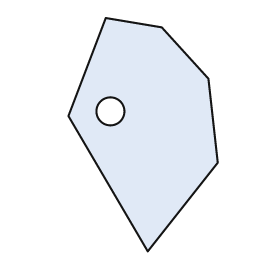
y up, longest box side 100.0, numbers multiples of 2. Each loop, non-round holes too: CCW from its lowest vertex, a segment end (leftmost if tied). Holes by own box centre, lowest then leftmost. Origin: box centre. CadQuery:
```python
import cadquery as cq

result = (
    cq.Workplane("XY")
    .moveTo(2.0, -50.0)
    .lineTo(32.0, -12.0)
    .lineTo(28.0, 24.0)
    .lineTo(8.0, 46.0)
    .lineTo(-16.0, 50.0)
    .lineTo(-32.0, 8.0)
    .close()
    .moveTo(-14.0, 10.0)
    .circle(6.0)
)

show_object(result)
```